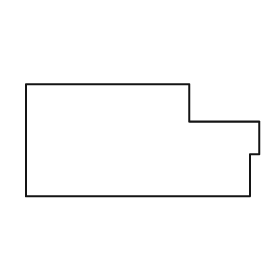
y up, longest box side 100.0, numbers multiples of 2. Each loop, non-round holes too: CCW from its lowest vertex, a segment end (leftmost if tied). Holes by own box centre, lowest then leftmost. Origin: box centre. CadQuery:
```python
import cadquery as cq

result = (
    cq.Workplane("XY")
    .moveTo(-50.0, -24.0)
    .lineTo(46.0, -24.0)
    .lineTo(46.0, -6.0)
    .lineTo(50.0, -6.0)
    .lineTo(50.0, 8.0)
    .lineTo(20.0, 8.0)
    .lineTo(20.0, 24.0)
    .lineTo(-50.0, 24.0)
    .close()
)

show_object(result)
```